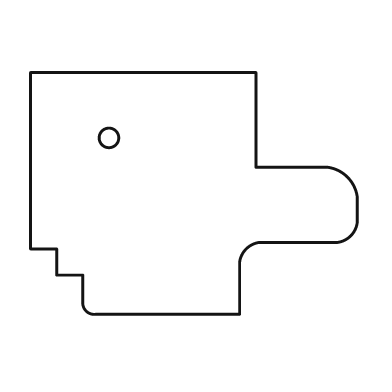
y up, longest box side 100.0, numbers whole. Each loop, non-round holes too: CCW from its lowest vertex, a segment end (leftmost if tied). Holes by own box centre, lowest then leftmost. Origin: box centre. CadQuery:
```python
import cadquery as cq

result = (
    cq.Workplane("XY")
    .moveTo(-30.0, -37.0)
    .lineTo(14.0, -37.0)
    .lineTo(14.0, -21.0)
    .threePointArc((16.0, -17.0), (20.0, -15.0))
    .lineTo(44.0, -15.0)
    .threePointArc((48.0, -13.0), (50.0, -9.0))
    .lineTo(50.0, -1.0)
    .threePointArc((47.0, 5.0), (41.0, 8.0))
    .lineTo(19.0, 8.0)
    .lineTo(19.0, 37.0)
    .lineTo(-50.0, 37.0)
    .lineTo(-50.0, -17.0)
    .lineTo(-42.0, -17.0)
    .lineTo(-42.0, -25.0)
    .lineTo(-34.0, -25.0)
    .lineTo(-34.0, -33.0)
    .threePointArc((-33.0, -36.0), (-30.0, -37.0))
    .close()
    .moveTo(-26.0, 17.0)
    .circle(3.0)
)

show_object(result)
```